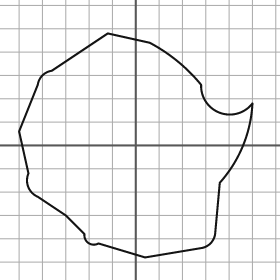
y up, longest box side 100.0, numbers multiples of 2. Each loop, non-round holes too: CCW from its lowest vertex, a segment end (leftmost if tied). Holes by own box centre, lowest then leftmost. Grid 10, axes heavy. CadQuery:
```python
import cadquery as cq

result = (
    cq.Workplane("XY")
    .moveTo(4.0, -48.0)
    .lineTo(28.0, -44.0)
    .threePointArc((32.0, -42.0), (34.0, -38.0))
    .lineTo(36.0, -16.0)
    .threePointArc((46.0, 0.0), (50.0, 18.0))
    .threePointArc((36.0, 14.0), (28.0, 26.0))
    .threePointArc((18.0, 36.0), (6.0, 44.0))
    .lineTo(-12.0, 48.0)
    .lineTo(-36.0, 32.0)
    .threePointArc((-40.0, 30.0), (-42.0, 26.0))
    .lineTo(-50.0, 6.0)
    .lineTo(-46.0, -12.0)
    .threePointArc((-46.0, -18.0), (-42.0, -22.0))
    .lineTo(-30.0, -30.0)
    .lineTo(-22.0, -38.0)
    .threePointArc((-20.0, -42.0), (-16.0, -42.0))
    .close()
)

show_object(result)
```